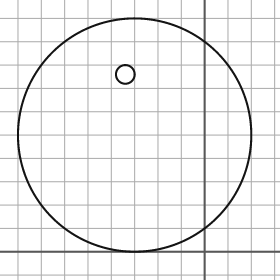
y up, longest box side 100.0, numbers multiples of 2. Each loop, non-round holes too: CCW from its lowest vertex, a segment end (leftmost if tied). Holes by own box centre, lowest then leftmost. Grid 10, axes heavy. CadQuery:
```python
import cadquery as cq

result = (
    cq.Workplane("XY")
    .moveTo(-30.0, 50.0)
    .circle(50.0)
    .moveTo(-34.0, 76.0)
    .circle(4.0)
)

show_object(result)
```